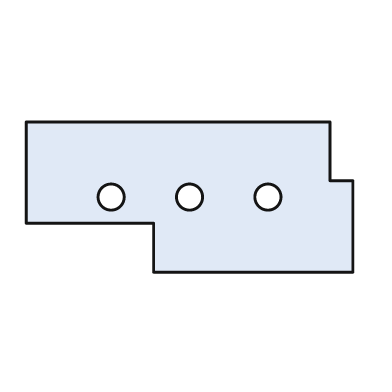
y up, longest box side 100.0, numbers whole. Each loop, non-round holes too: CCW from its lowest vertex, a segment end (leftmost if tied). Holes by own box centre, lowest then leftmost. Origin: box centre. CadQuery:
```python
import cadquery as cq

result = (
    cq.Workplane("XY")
    .moveTo(-11.0, -23.0)
    .lineTo(50.0, -23.0)
    .lineTo(50.0, 5.0)
    .lineTo(43.0, 5.0)
    .lineTo(43.0, 23.0)
    .lineTo(-50.0, 23.0)
    .lineTo(-50.0, -8.0)
    .lineTo(-11.0, -8.0)
    .close()
    .moveTo(-24.0, 0.0)
    .circle(4.0)
    .moveTo(0.0, 0.0)
    .circle(4.0)
    .moveTo(24.0, 0.0)
    .circle(4.0)
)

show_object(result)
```